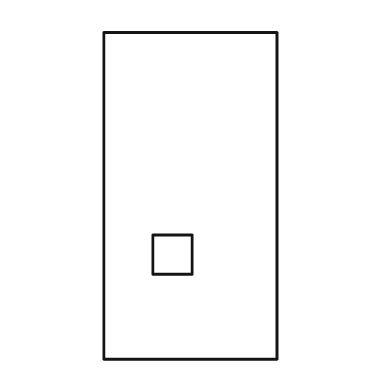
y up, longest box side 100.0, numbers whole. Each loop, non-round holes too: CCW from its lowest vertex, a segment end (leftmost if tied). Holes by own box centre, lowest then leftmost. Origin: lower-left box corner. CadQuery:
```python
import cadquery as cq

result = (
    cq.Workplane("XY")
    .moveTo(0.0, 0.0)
    .lineTo(53.0, 0.0)
    .lineTo(53.0, 100.0)
    .lineTo(0.0, 100.0)
    .close()
    .moveTo(15.0, 26.0)
    .lineTo(27.0, 26.0)
    .lineTo(27.0, 38.0)
    .lineTo(15.0, 38.0)
    .close()
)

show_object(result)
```